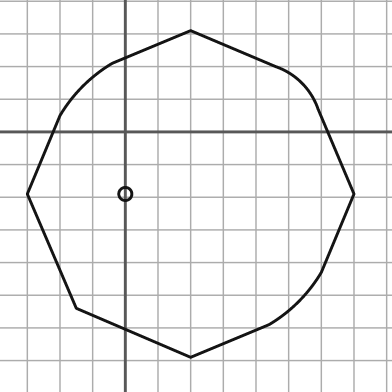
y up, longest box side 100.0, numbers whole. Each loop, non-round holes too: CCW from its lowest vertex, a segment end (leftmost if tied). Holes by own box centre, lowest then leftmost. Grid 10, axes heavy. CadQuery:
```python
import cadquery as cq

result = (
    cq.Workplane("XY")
    .moveTo(20.0, -69.0)
    .lineTo(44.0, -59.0)
    .threePointArc((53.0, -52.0), (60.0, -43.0))
    .lineTo(70.0, -19.0)
    .lineTo(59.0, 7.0)
    .threePointArc((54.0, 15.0), (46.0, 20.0))
    .lineTo(20.0, 31.0)
    .lineTo(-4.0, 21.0)
    .threePointArc((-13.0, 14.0), (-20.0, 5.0))
    .lineTo(-30.0, -19.0)
    .lineTo(-15.0, -54.0)
    .close()
    .moveTo(0.0, -19.0)
    .circle(2.0)
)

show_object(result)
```